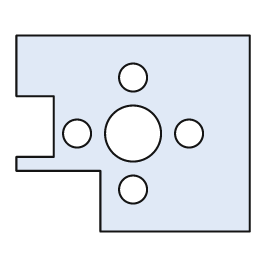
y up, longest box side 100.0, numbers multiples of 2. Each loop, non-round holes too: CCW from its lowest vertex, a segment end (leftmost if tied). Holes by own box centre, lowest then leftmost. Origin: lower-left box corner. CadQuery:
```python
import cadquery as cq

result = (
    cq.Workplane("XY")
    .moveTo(36.0, 0.0)
    .lineTo(100.0, 0.0)
    .lineTo(100.0, 84.0)
    .lineTo(0.0, 84.0)
    .lineTo(0.0, 58.0)
    .lineTo(16.0, 58.0)
    .lineTo(16.0, 32.0)
    .lineTo(0.0, 32.0)
    .lineTo(0.0, 26.0)
    .lineTo(36.0, 26.0)
    .close()
    .moveTo(50.0, 18.0)
    .circle(6.0)
    .moveTo(26.0, 42.0)
    .circle(6.0)
    .moveTo(50.0, 42.0)
    .circle(12.0)
    .moveTo(74.0, 42.0)
    .circle(6.0)
    .moveTo(50.0, 66.0)
    .circle(6.0)
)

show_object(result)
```